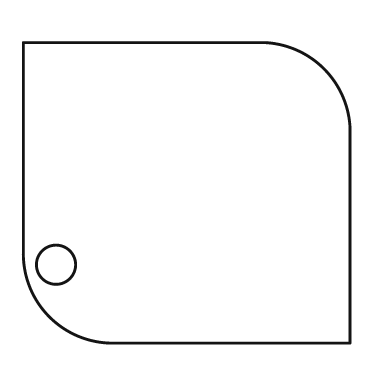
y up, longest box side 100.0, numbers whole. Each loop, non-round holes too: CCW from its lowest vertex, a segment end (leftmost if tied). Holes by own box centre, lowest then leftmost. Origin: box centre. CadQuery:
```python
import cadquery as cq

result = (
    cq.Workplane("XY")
    .moveTo(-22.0, -46.0)
    .lineTo(50.0, -46.0)
    .lineTo(50.0, 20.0)
    .threePointArc((42.0, 38.0), (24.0, 46.0))
    .lineTo(-50.0, 46.0)
    .lineTo(-50.0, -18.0)
    .threePointArc((-42.0, -38.0), (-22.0, -46.0))
    .close()
    .moveTo(-40.0, -22.0)
    .circle(6.0)
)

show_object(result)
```